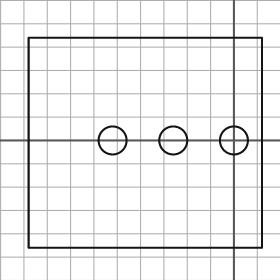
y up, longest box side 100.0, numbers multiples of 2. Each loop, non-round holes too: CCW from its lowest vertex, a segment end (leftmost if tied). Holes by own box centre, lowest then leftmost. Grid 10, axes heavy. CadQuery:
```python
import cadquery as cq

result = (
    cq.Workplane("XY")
    .moveTo(-88.0, -46.0)
    .lineTo(12.0, -46.0)
    .lineTo(12.0, 44.0)
    .lineTo(-88.0, 44.0)
    .close()
    .moveTo(-52.0, 0.0)
    .circle(6.0)
    .moveTo(-26.0, 0.0)
    .circle(6.0)
    .moveTo(0.0, 0.0)
    .circle(6.0)
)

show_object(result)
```